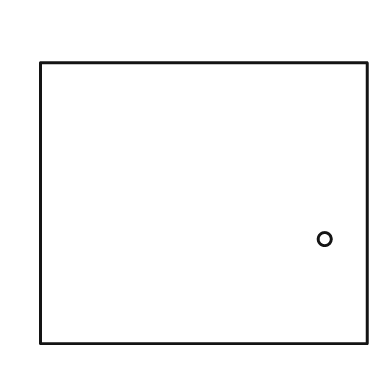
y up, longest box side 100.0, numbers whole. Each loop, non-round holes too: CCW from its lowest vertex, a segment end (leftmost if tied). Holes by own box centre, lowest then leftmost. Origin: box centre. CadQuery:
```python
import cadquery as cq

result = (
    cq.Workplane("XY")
    .moveTo(-50.0, -43.0)
    .lineTo(50.0, -43.0)
    .lineTo(50.0, 43.0)
    .lineTo(-50.0, 43.0)
    .close()
    .moveTo(37.0, -11.0)
    .circle(2.0)
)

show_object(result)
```